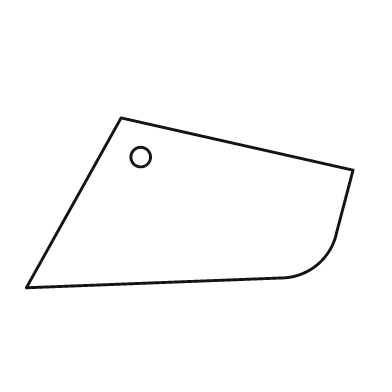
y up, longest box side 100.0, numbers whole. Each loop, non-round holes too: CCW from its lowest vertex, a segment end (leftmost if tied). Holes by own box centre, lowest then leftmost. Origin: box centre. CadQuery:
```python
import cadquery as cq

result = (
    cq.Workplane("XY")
    .moveTo(-50.0, -26.0)
    .lineTo(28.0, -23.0)
    .threePointArc((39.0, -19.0), (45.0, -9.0))
    .lineTo(50.0, 10.0)
    .lineTo(-21.0, 26.0)
    .close()
    .moveTo(-15.0, 14.0)
    .circle(3.0)
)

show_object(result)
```